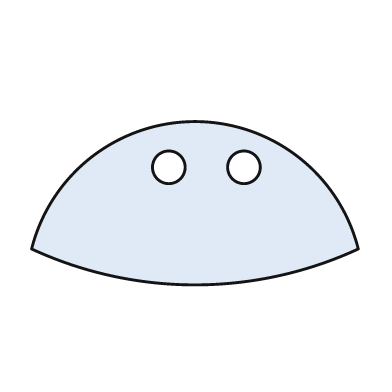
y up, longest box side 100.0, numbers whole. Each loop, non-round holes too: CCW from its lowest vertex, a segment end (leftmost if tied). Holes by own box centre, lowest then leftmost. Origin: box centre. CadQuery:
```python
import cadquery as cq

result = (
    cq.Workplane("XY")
    .moveTo(-50.0, -14.0)
    .threePointArc((0.0, -25.0), (50.0, -14.0))
    .threePointArc((0.0, 25.0), (-50.0, -14.0))
    .close()
    .moveTo(-8.0, 11.0)
    .circle(5.0)
    .moveTo(15.0, 11.0)
    .circle(5.0)
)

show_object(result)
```